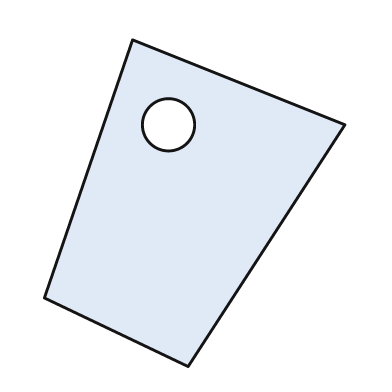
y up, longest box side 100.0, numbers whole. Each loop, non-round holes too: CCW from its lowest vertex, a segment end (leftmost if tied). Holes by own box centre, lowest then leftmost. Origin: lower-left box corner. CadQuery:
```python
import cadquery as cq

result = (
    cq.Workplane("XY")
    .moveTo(44.0, 0.0)
    .lineTo(92.0, 74.0)
    .lineTo(27.0, 100.0)
    .lineTo(0.0, 21.0)
    .close()
    .moveTo(38.0, 74.0)
    .circle(8.0)
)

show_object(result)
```